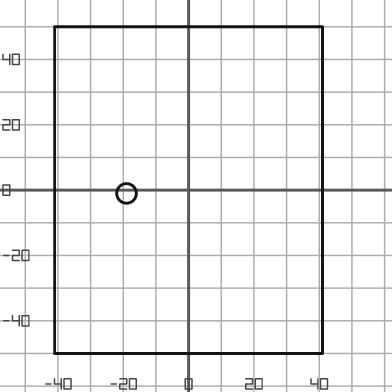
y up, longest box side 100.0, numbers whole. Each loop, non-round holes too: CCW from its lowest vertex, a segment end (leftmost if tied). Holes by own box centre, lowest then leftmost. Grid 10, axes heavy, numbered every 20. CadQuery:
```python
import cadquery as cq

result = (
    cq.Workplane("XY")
    .moveTo(-41.0, -50.0)
    .lineTo(41.0, -50.0)
    .lineTo(41.0, 50.0)
    .lineTo(-41.0, 50.0)
    .close()
    .moveTo(-19.0, -1.0)
    .circle(3.0)
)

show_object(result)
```